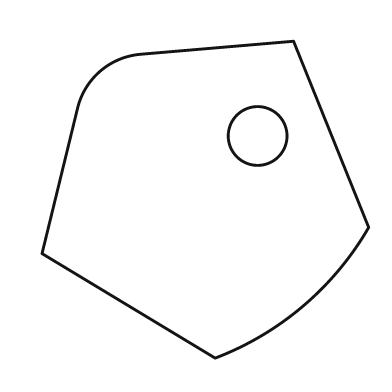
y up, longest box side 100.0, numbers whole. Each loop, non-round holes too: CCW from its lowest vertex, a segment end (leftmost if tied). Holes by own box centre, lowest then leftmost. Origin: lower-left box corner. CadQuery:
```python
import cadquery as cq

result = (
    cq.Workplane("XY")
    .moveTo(53.0, 0.0)
    .threePointArc((80.0, 16.0), (100.0, 40.0))
    .lineTo(77.0, 97.0)
    .lineTo(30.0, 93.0)
    .threePointArc((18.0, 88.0), (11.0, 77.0))
    .lineTo(0.0, 32.0)
    .close()
    .moveTo(66.0, 68.0)
    .circle(9.0)
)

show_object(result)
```